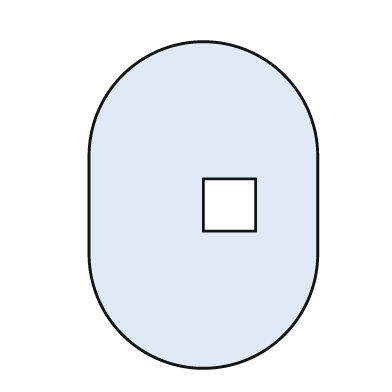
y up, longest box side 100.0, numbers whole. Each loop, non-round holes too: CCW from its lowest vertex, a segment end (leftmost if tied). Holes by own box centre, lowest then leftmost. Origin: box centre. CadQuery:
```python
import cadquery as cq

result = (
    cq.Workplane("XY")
    .moveTo(-35.0, -15.0)
    .threePointArc((0.0, -50.0), (35.0, -15.0))
    .lineTo(35.0, 15.0)
    .threePointArc((0.0, 50.0), (-35.0, 15.0))
    .close()
    .moveTo(0.0, -8.0)
    .lineTo(16.0, -8.0)
    .lineTo(16.0, 8.0)
    .lineTo(0.0, 8.0)
    .close()
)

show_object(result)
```